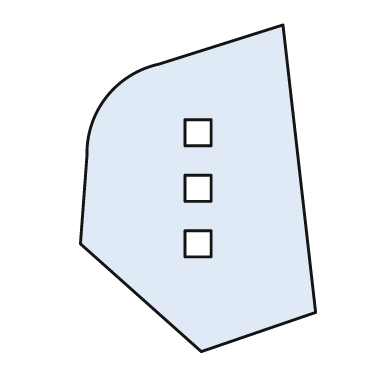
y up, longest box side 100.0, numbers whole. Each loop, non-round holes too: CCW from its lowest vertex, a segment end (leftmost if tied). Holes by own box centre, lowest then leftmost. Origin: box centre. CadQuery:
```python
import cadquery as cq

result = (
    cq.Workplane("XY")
    .moveTo(1.0, -50.0)
    .lineTo(36.0, -38.0)
    .lineTo(26.0, 50.0)
    .lineTo(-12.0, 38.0)
    .threePointArc((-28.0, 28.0), (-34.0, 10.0))
    .lineTo(-36.0, -17.0)
    .close()
    .moveTo(-4.0, -21.0)
    .lineTo(4.0, -21.0)
    .lineTo(4.0, -13.0)
    .lineTo(-4.0, -13.0)
    .close()
    .moveTo(-4.0, -4.0)
    .lineTo(4.0, -4.0)
    .lineTo(4.0, 4.0)
    .lineTo(-4.0, 4.0)
    .close()
    .moveTo(-4.0, 13.0)
    .lineTo(4.0, 13.0)
    .lineTo(4.0, 21.0)
    .lineTo(-4.0, 21.0)
    .close()
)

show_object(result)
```